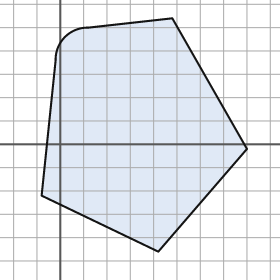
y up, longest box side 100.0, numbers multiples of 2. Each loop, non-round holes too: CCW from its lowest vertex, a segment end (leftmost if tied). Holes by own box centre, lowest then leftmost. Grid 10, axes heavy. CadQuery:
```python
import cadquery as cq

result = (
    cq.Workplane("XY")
    .moveTo(42.0, -46.0)
    .lineTo(80.0, -2.0)
    .lineTo(48.0, 54.0)
    .lineTo(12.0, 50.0)
    .threePointArc((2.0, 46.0), (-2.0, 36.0))
    .lineTo(-8.0, -22.0)
    .close()
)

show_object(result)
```